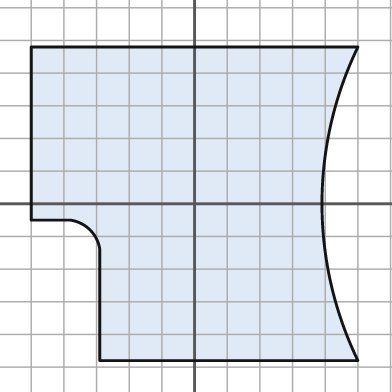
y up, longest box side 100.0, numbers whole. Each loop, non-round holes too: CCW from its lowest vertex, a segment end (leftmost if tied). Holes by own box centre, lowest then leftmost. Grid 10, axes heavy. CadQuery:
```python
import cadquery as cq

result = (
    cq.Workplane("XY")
    .moveTo(-29.0, -48.0)
    .lineTo(50.0, -48.0)
    .threePointArc((39.0, 0.0), (50.0, 48.0))
    .lineTo(-50.0, 48.0)
    .lineTo(-50.0, -5.0)
    .lineTo(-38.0, -5.0)
    .threePointArc((-32.0, -8.0), (-29.0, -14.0))
    .close()
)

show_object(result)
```